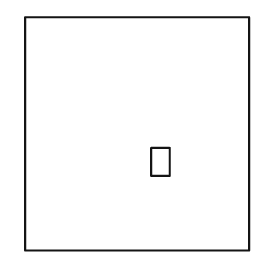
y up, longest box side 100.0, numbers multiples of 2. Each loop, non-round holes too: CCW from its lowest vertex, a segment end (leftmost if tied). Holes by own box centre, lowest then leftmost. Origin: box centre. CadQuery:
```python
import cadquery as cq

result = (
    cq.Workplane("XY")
    .moveTo(-48.0, -50.0)
    .lineTo(48.0, -50.0)
    .lineTo(48.0, 50.0)
    .lineTo(-48.0, 50.0)
    .close()
    .moveTo(6.0, -18.0)
    .lineTo(14.0, -18.0)
    .lineTo(14.0, -6.0)
    .lineTo(6.0, -6.0)
    .close()
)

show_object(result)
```